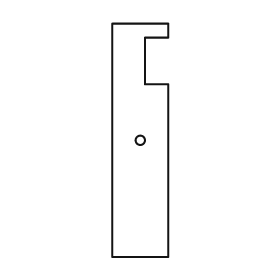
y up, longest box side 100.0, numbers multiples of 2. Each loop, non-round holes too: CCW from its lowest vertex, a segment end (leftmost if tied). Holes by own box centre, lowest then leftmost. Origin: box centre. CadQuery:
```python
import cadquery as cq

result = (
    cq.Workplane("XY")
    .moveTo(-12.0, -50.0)
    .lineTo(12.0, -50.0)
    .lineTo(12.0, 24.0)
    .lineTo(2.0, 24.0)
    .lineTo(2.0, 44.0)
    .lineTo(12.0, 44.0)
    .lineTo(12.0, 50.0)
    .lineTo(-12.0, 50.0)
    .close()
    .moveTo(0.0, 0.0)
    .circle(2.0)
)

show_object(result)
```